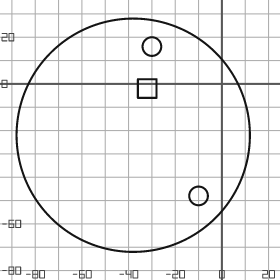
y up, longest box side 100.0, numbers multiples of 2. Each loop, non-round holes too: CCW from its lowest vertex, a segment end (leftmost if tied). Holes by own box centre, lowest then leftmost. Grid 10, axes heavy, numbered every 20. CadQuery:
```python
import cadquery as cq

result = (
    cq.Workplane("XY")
    .moveTo(-38.0, -22.0)
    .circle(50.0)
    .moveTo(-10.0, -48.0)
    .circle(4.0)
    .moveTo(-36.0, -6.0)
    .lineTo(-28.0, -6.0)
    .lineTo(-28.0, 2.0)
    .lineTo(-36.0, 2.0)
    .close()
    .moveTo(-30.0, 16.0)
    .circle(4.0)
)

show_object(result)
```